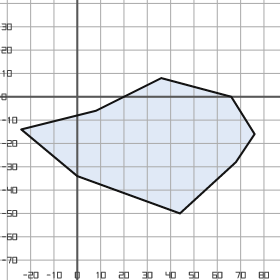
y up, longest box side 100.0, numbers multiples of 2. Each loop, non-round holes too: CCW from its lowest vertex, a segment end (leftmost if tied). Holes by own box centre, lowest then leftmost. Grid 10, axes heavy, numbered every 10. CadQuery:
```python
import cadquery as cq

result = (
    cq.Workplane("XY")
    .moveTo(44.0, -50.0)
    .lineTo(68.0, -28.0)
    .lineTo(76.0, -16.0)
    .lineTo(66.0, 0.0)
    .lineTo(36.0, 8.0)
    .lineTo(8.0, -6.0)
    .lineTo(-24.0, -14.0)
    .lineTo(0.0, -34.0)
    .close()
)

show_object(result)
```